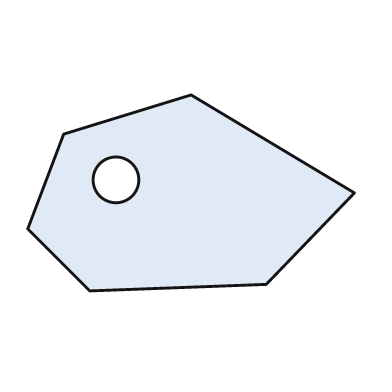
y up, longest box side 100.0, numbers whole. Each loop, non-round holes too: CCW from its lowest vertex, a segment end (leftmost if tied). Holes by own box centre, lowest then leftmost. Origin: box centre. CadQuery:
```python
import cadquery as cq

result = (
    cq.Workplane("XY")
    .moveTo(-31.0, -30.0)
    .lineTo(23.0, -28.0)
    .lineTo(50.0, 0.0)
    .lineTo(0.0, 30.0)
    .lineTo(-39.0, 18.0)
    .lineTo(-50.0, -11.0)
    .close()
    .moveTo(-23.0, 4.0)
    .circle(7.0)
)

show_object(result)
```